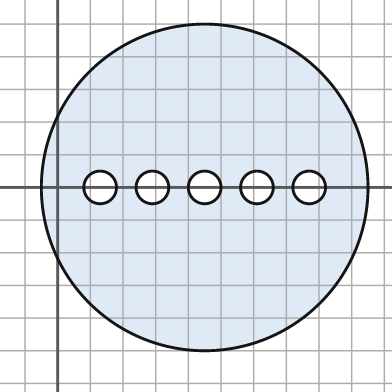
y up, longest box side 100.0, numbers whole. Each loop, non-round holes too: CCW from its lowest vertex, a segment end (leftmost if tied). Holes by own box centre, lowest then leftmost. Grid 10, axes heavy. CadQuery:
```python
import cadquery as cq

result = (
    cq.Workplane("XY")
    .moveTo(45.0, 0.0)
    .circle(50.0)
    .moveTo(13.0, 0.0)
    .circle(5.0)
    .moveTo(29.0, 0.0)
    .circle(5.0)
    .moveTo(45.0, 0.0)
    .circle(5.0)
    .moveTo(61.0, 0.0)
    .circle(5.0)
    .moveTo(77.0, 0.0)
    .circle(5.0)
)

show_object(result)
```